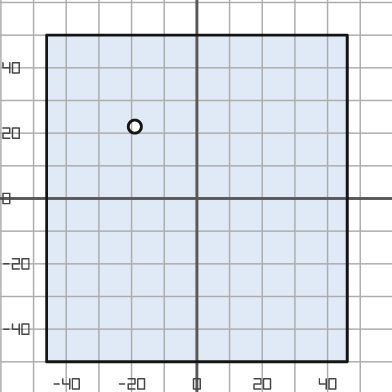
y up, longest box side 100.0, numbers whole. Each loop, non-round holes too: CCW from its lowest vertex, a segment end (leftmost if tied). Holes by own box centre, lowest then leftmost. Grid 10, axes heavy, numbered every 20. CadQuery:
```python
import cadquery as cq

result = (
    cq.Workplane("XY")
    .moveTo(-46.0, -50.0)
    .lineTo(46.0, -50.0)
    .lineTo(46.0, 50.0)
    .lineTo(-46.0, 50.0)
    .close()
    .moveTo(-19.0, 22.0)
    .circle(2.0)
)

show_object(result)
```